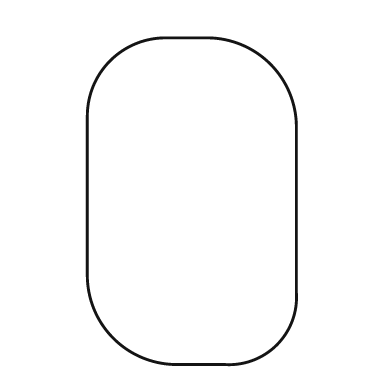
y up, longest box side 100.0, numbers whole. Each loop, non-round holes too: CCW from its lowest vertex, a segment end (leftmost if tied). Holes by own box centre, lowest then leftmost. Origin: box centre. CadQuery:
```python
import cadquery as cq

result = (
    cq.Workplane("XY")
    .moveTo(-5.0, -50.0)
    .lineTo(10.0, -50.0)
    .threePointArc((26.0, -44.0), (32.0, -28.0))
    .lineTo(32.0, 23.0)
    .threePointArc((24.0, 42.0), (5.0, 50.0))
    .lineTo(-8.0, 50.0)
    .threePointArc((-25.0, 43.0), (-32.0, 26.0))
    .lineTo(-32.0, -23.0)
    .threePointArc((-24.0, -42.0), (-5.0, -50.0))
    .close()
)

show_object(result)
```